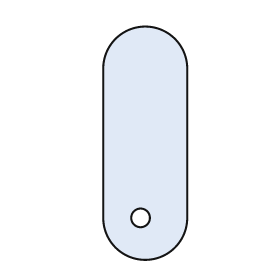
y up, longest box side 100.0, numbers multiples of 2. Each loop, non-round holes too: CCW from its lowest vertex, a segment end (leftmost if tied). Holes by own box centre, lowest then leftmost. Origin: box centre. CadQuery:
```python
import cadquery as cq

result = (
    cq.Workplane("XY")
    .moveTo(-18.0, -32.0)
    .threePointArc((0.0, -50.0), (18.0, -32.0))
    .lineTo(18.0, 32.0)
    .threePointArc((0.0, 50.0), (-18.0, 32.0))
    .close()
    .moveTo(-2.0, -32.0)
    .circle(4.0)
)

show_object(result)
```